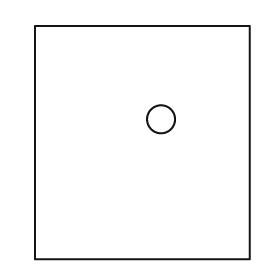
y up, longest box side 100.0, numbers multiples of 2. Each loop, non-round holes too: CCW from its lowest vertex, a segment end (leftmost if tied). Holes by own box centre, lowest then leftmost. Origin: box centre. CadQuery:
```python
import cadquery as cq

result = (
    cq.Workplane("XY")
    .moveTo(-46.0, -50.0)
    .lineTo(46.0, -50.0)
    .lineTo(46.0, 50.0)
    .lineTo(-46.0, 50.0)
    .close()
    .moveTo(8.0, 10.0)
    .circle(6.0)
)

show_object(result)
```